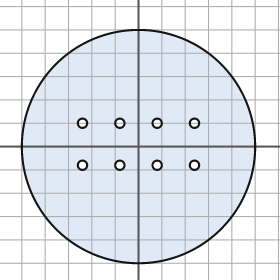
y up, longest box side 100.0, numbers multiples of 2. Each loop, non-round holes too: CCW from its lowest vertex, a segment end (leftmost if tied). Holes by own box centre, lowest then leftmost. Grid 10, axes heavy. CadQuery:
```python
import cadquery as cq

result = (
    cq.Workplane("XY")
    .moveTo(0.0, 0.0)
    .circle(50.0)
    .moveTo(-24.0, -8.0)
    .circle(2.0)
    .moveTo(-8.0, -8.0)
    .circle(2.0)
    .moveTo(8.0, -8.0)
    .circle(2.0)
    .moveTo(24.0, -8.0)
    .circle(2.0)
    .moveTo(-24.0, 10.0)
    .circle(2.0)
    .moveTo(-8.0, 10.0)
    .circle(2.0)
    .moveTo(8.0, 10.0)
    .circle(2.0)
    .moveTo(24.0, 10.0)
    .circle(2.0)
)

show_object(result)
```